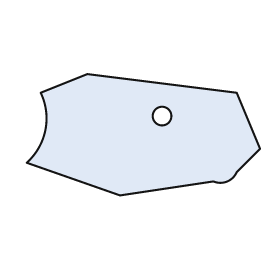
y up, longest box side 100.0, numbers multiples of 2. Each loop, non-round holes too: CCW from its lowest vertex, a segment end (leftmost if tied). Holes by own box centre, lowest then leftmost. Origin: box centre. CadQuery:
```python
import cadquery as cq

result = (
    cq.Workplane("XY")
    .moveTo(-10.0, -26.0)
    .lineTo(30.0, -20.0)
    .threePointArc((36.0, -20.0), (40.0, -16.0))
    .lineTo(50.0, -6.0)
    .lineTo(40.0, 18.0)
    .lineTo(-24.0, 26.0)
    .lineTo(-44.0, 18.0)
    .threePointArc((-42.0, 2.0), (-50.0, -12.0))
    .close()
    .moveTo(8.0, 8.0)
    .circle(4.0)
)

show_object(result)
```